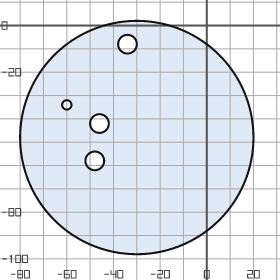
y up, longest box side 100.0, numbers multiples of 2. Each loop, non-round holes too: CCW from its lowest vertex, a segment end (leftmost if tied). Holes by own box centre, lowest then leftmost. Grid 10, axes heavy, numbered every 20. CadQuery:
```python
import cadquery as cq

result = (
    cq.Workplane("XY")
    .moveTo(-30.0, -48.0)
    .circle(50.0)
    .moveTo(-48.0, -58.0)
    .circle(4.0)
    .moveTo(-46.0, -42.0)
    .circle(4.0)
    .moveTo(-60.0, -34.0)
    .circle(2.0)
    .moveTo(-34.0, -8.0)
    .circle(4.0)
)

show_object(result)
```